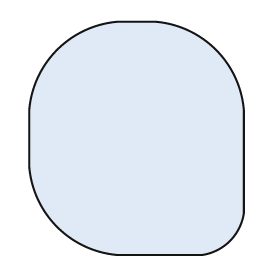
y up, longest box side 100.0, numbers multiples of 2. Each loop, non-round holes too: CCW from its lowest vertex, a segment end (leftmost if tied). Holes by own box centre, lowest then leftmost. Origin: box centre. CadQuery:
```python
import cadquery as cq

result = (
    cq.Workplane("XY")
    .moveTo(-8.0, -50.0)
    .lineTo(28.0, -50.0)
    .threePointArc((40.0, -44.0), (46.0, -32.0))
    .lineTo(46.0, 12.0)
    .threePointArc((34.0, 38.0), (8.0, 50.0))
    .lineTo(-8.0, 50.0)
    .threePointArc((-34.0, 38.0), (-46.0, 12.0))
    .lineTo(-46.0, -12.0)
    .threePointArc((-34.0, -38.0), (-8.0, -50.0))
    .close()
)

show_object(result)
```